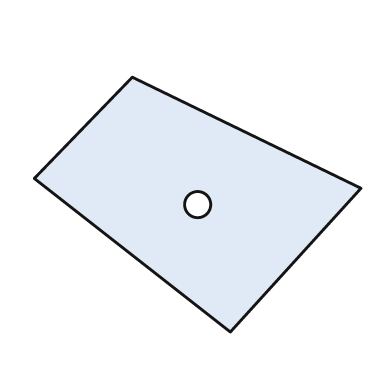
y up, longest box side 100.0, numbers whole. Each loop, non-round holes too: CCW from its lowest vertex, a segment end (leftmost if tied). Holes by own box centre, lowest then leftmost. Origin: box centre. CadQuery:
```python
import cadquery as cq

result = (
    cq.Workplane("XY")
    .moveTo(10.0, -39.0)
    .lineTo(50.0, 5.0)
    .lineTo(-20.0, 39.0)
    .lineTo(-50.0, 8.0)
    .close()
    .moveTo(0.0, 0.0)
    .circle(4.0)
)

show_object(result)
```